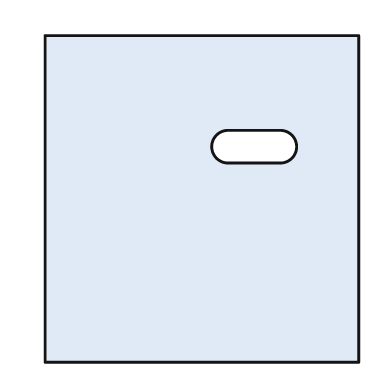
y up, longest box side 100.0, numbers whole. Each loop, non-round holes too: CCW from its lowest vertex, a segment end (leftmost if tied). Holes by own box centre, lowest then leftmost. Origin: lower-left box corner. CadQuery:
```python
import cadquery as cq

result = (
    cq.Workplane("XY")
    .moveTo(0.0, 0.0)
    .lineTo(96.0, 0.0)
    .lineTo(96.0, 100.0)
    .lineTo(0.0, 100.0)
    .close()
    .moveTo(56.0, 61.0)
    .lineTo(72.0, 61.0)
    .threePointArc((77.0, 66.0), (72.0, 71.0))
    .lineTo(56.0, 71.0)
    .threePointArc((51.0, 66.0), (56.0, 61.0))
    .close()
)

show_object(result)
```